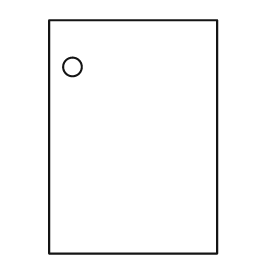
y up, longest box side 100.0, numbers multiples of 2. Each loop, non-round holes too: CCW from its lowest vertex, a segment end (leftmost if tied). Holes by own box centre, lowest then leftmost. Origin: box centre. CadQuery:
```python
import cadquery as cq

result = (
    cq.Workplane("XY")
    .moveTo(-36.0, -50.0)
    .lineTo(36.0, -50.0)
    .lineTo(36.0, 50.0)
    .lineTo(-36.0, 50.0)
    .close()
    .moveTo(-26.0, 30.0)
    .circle(4.0)
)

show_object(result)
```